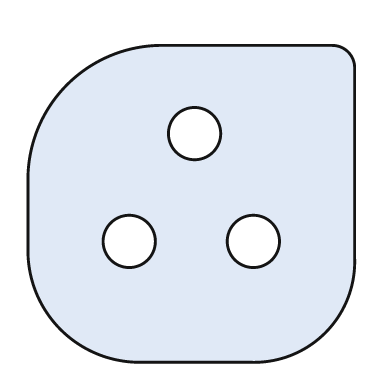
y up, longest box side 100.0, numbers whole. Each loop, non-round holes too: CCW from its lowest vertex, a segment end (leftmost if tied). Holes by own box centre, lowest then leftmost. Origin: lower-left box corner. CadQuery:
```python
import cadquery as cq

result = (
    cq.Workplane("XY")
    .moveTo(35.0, 0.0)
    .lineTo(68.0, 0.0)
    .threePointArc((91.0, 9.0), (100.0, 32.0))
    .lineTo(100.0, 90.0)
    .threePointArc((98.0, 95.0), (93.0, 97.0))
    .lineTo(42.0, 97.0)
    .threePointArc((12.0, 85.0), (0.0, 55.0))
    .lineTo(0.0, 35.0)
    .threePointArc((10.0, 10.0), (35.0, 0.0))
    .close()
    .moveTo(31.0, 37.0)
    .circle(8.0)
    .moveTo(69.0, 37.0)
    .circle(8.0)
    .moveTo(51.0, 70.0)
    .circle(8.0)
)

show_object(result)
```